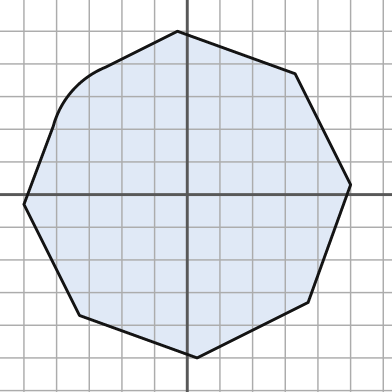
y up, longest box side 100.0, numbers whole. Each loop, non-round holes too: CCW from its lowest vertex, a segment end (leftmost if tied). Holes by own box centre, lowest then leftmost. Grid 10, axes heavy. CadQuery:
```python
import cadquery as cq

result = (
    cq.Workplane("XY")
    .moveTo(3.0, -50.0)
    .lineTo(37.0, -33.0)
    .lineTo(50.0, 3.0)
    .lineTo(33.0, 37.0)
    .lineTo(-3.0, 50.0)
    .lineTo(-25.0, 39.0)
    .threePointArc((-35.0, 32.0), (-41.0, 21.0))
    .lineTo(-50.0, -3.0)
    .lineTo(-33.0, -37.0)
    .close()
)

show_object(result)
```